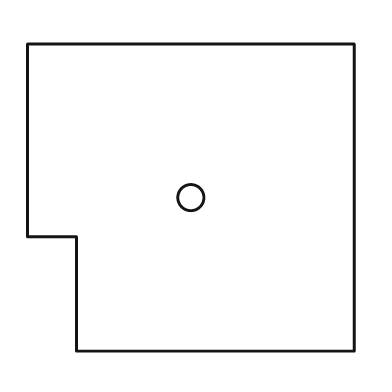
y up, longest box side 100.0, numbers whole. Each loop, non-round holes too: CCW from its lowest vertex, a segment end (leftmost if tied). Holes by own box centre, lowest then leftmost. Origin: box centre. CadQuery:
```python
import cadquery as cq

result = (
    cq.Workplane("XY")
    .moveTo(-35.0, -47.0)
    .lineTo(50.0, -47.0)
    .lineTo(50.0, 47.0)
    .lineTo(-50.0, 47.0)
    .lineTo(-50.0, -12.0)
    .lineTo(-35.0, -12.0)
    .close()
    .moveTo(0.0, 0.0)
    .circle(4.0)
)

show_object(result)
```